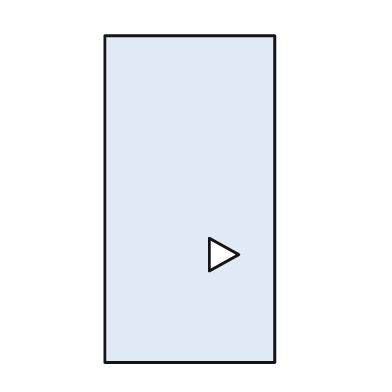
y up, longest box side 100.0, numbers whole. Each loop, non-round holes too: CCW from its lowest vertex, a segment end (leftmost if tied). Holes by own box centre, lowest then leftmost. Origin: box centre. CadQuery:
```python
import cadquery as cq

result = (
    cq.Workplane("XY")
    .moveTo(-26.0, -50.0)
    .lineTo(26.0, -50.0)
    .lineTo(26.0, 50.0)
    .lineTo(-26.0, 50.0)
    .close()
    .moveTo(6.0, -22.0)
    .lineTo(15.0, -17.0)
    .lineTo(6.0, -12.0)
    .close()
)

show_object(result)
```